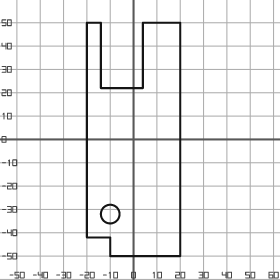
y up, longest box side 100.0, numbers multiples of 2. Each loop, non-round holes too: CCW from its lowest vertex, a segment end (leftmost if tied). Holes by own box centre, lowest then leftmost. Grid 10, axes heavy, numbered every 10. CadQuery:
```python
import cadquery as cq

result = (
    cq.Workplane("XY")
    .moveTo(-10.0, -50.0)
    .lineTo(20.0, -50.0)
    .lineTo(20.0, 50.0)
    .lineTo(4.0, 50.0)
    .lineTo(4.0, 22.0)
    .lineTo(-14.0, 22.0)
    .lineTo(-14.0, 50.0)
    .lineTo(-20.0, 50.0)
    .lineTo(-20.0, -42.0)
    .lineTo(-10.0, -42.0)
    .close()
    .moveTo(-10.0, -32.0)
    .circle(4.0)
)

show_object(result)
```